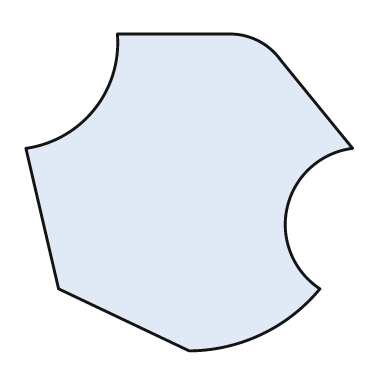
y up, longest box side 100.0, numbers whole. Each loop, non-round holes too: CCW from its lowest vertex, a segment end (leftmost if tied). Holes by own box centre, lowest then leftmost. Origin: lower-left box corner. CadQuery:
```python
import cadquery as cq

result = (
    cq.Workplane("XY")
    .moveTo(50.0, 0.0)
    .threePointArc((72.0, 5.0), (90.0, 19.0))
    .threePointArc((80.0, 44.0), (100.0, 62.0))
    .lineTo(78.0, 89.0)
    .threePointArc((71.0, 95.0), (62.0, 97.0))
    .lineTo(28.0, 97.0)
    .threePointArc((21.0, 74.0), (0.0, 62.0))
    .lineTo(10.0, 19.0)
    .close()
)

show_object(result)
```